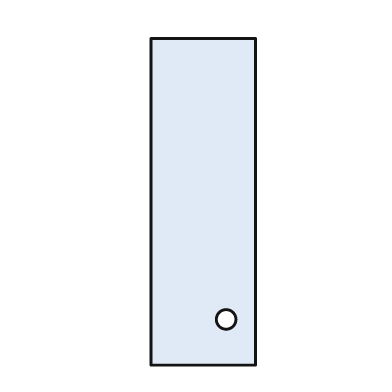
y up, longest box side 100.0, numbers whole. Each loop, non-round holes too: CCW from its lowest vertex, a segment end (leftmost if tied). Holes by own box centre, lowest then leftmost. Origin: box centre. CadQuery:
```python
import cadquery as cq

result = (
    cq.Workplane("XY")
    .moveTo(-16.0, -50.0)
    .lineTo(16.0, -50.0)
    .lineTo(16.0, 50.0)
    .lineTo(-16.0, 50.0)
    .close()
    .moveTo(7.0, -36.0)
    .circle(3.0)
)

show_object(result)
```